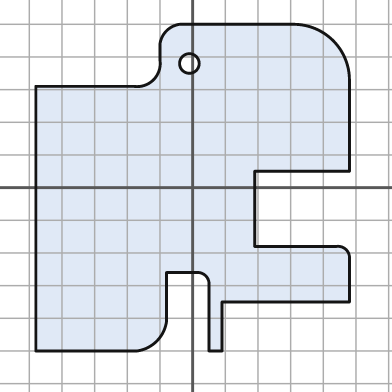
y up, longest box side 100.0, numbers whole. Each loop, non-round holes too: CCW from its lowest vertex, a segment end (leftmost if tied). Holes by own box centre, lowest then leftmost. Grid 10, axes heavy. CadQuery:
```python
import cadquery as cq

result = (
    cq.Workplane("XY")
    .moveTo(-48.0, -50.0)
    .lineTo(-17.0, -50.0)
    .threePointArc((-11.0, -47.0), (-8.0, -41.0))
    .lineTo(-8.0, -26.0)
    .lineTo(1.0, -26.0)
    .threePointArc((4.0, -27.0), (5.0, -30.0))
    .lineTo(5.0, -50.0)
    .lineTo(9.0, -50.0)
    .lineTo(9.0, -35.0)
    .lineTo(48.0, -35.0)
    .lineTo(48.0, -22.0)
    .threePointArc((47.0, -19.0), (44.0, -18.0))
    .lineTo(19.0, -18.0)
    .lineTo(19.0, 5.0)
    .lineTo(48.0, 5.0)
    .lineTo(48.0, 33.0)
    .threePointArc((43.0, 45.0), (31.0, 50.0))
    .lineTo(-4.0, 50.0)
    .threePointArc((-8.0, 48.0), (-10.0, 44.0))
    .lineTo(-10.0, 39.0)
    .threePointArc((-12.0, 33.0), (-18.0, 31.0))
    .lineTo(-48.0, 31.0)
    .close()
    .moveTo(-1.0, 38.0)
    .circle(3.0)
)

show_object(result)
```